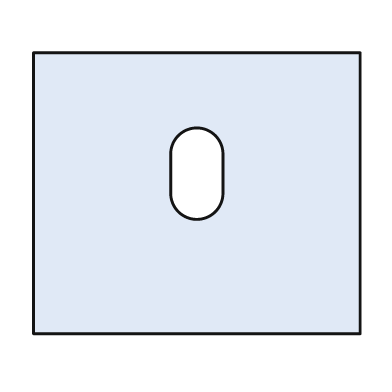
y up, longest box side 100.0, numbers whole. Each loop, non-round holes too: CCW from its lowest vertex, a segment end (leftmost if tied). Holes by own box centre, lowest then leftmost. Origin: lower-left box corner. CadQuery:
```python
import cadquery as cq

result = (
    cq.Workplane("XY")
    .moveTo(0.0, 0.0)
    .lineTo(100.0, 0.0)
    .lineTo(100.0, 86.0)
    .lineTo(0.0, 86.0)
    .close()
    .moveTo(42.0, 43.0)
    .threePointArc((50.0, 35.0), (58.0, 43.0))
    .lineTo(58.0, 55.0)
    .threePointArc((50.0, 63.0), (42.0, 55.0))
    .close()
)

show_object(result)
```